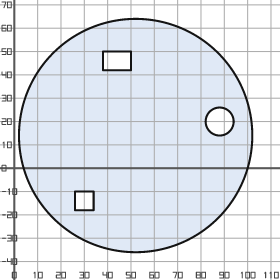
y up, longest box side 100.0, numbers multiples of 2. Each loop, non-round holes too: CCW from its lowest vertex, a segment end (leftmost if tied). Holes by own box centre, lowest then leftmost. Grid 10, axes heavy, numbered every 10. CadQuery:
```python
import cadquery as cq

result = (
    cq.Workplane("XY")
    .moveTo(52.0, 14.0)
    .circle(50.0)
    .moveTo(26.0, -18.0)
    .lineTo(34.0, -18.0)
    .lineTo(34.0, -10.0)
    .lineTo(26.0, -10.0)
    .close()
    .moveTo(88.0, 20.0)
    .circle(6.0)
    .moveTo(38.0, 42.0)
    .lineTo(50.0, 42.0)
    .lineTo(50.0, 50.0)
    .lineTo(38.0, 50.0)
    .close()
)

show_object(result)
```